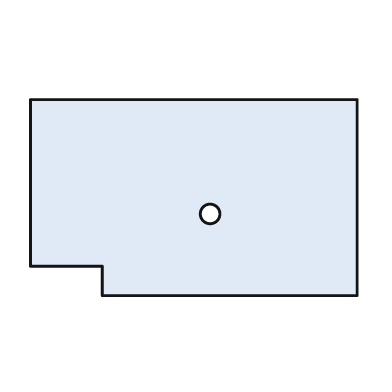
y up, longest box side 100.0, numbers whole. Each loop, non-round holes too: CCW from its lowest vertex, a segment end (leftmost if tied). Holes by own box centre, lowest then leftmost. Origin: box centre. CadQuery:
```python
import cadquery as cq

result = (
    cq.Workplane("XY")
    .moveTo(-28.0, -30.0)
    .lineTo(50.0, -30.0)
    .lineTo(50.0, 30.0)
    .lineTo(-50.0, 30.0)
    .lineTo(-50.0, -21.0)
    .lineTo(-28.0, -21.0)
    .close()
    .moveTo(5.0, -5.0)
    .circle(3.0)
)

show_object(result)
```